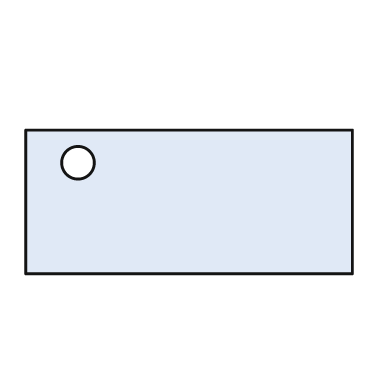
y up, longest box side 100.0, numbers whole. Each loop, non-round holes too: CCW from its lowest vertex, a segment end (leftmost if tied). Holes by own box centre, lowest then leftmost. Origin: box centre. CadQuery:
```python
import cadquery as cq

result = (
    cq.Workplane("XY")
    .moveTo(-50.0, -22.0)
    .lineTo(50.0, -22.0)
    .lineTo(50.0, 22.0)
    .lineTo(-50.0, 22.0)
    .close()
    .moveTo(-34.0, 12.0)
    .circle(5.0)
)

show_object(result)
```